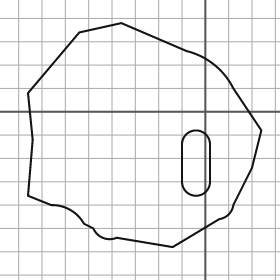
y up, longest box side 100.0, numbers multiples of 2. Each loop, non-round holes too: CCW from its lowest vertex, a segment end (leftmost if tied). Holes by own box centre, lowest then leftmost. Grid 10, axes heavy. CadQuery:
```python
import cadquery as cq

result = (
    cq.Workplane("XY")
    .moveTo(-14.0, -58.0)
    .lineTo(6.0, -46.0)
    .threePointArc((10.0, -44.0), (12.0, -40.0))
    .lineTo(20.0, -24.0)
    .lineTo(24.0, -8.0)
    .lineTo(12.0, 10.0)
    .threePointArc((4.0, 20.0), (-8.0, 26.0))
    .lineTo(-36.0, 38.0)
    .lineTo(-54.0, 34.0)
    .lineTo(-76.0, 8.0)
    .lineTo(-74.0, -12.0)
    .lineTo(-76.0, -36.0)
    .lineTo(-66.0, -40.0)
    .threePointArc((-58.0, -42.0), (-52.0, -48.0))
    .lineTo(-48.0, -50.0)
    .threePointArc((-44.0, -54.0), (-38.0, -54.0))
    .close()
    .moveTo(-10.0, -30.0)
    .threePointArc((-4.0, -36.0), (2.0, -30.0))
    .lineTo(2.0, -14.0)
    .threePointArc((-4.0, -8.0), (-10.0, -14.0))
    .close()
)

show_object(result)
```